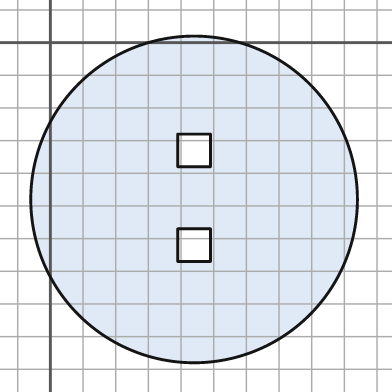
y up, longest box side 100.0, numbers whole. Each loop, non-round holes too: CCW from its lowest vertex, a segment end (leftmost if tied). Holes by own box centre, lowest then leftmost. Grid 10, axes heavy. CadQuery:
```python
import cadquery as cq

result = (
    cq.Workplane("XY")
    .moveTo(44.0, -48.0)
    .circle(50.0)
    .moveTo(39.0, -67.0)
    .lineTo(49.0, -67.0)
    .lineTo(49.0, -57.0)
    .lineTo(39.0, -57.0)
    .close()
    .moveTo(39.0, -38.0)
    .lineTo(49.0, -38.0)
    .lineTo(49.0, -28.0)
    .lineTo(39.0, -28.0)
    .close()
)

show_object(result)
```